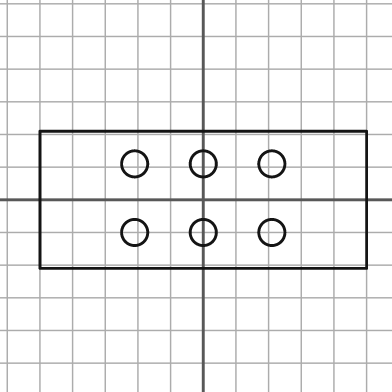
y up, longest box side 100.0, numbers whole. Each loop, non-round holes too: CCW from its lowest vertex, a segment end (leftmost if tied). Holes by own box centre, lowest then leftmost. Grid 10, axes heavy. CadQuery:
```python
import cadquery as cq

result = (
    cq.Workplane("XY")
    .moveTo(-50.0, -21.0)
    .lineTo(50.0, -21.0)
    .lineTo(50.0, 21.0)
    .lineTo(-50.0, 21.0)
    .close()
    .moveTo(-21.0, -10.0)
    .circle(4.0)
    .moveTo(0.0, -10.0)
    .circle(4.0)
    .moveTo(21.0, -10.0)
    .circle(4.0)
    .moveTo(-21.0, 11.0)
    .circle(4.0)
    .moveTo(0.0, 11.0)
    .circle(4.0)
    .moveTo(21.0, 11.0)
    .circle(4.0)
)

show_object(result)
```